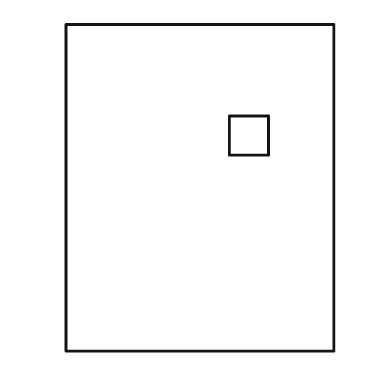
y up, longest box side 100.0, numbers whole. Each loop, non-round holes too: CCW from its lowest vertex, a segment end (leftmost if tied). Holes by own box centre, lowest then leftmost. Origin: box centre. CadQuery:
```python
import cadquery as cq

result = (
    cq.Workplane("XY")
    .moveTo(-41.0, -50.0)
    .lineTo(41.0, -50.0)
    .lineTo(41.0, 50.0)
    .lineTo(-41.0, 50.0)
    .close()
    .moveTo(9.0, 10.0)
    .lineTo(21.0, 10.0)
    .lineTo(21.0, 22.0)
    .lineTo(9.0, 22.0)
    .close()
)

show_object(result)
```